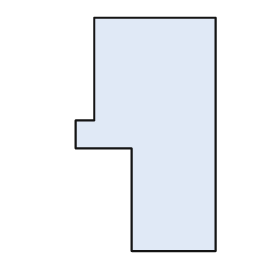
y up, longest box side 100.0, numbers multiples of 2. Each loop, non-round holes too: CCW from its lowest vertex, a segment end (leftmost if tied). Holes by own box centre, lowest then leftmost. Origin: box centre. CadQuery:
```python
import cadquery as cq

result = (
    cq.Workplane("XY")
    .moveTo(-6.0, -50.0)
    .lineTo(30.0, -50.0)
    .lineTo(30.0, 50.0)
    .lineTo(-22.0, 50.0)
    .lineTo(-22.0, 6.0)
    .lineTo(-30.0, 6.0)
    .lineTo(-30.0, -6.0)
    .lineTo(-6.0, -6.0)
    .close()
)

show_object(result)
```